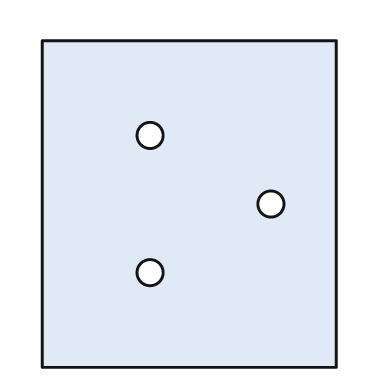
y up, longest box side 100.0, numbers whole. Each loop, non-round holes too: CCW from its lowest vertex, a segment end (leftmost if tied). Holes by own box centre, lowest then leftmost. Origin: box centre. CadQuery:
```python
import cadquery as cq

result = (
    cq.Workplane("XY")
    .moveTo(-45.0, -50.0)
    .lineTo(45.0, -50.0)
    .lineTo(45.0, 50.0)
    .lineTo(-45.0, 50.0)
    .close()
    .moveTo(-12.0, -21.0)
    .circle(4.0)
    .moveTo(25.0, 0.0)
    .circle(4.0)
    .moveTo(-12.0, 21.0)
    .circle(4.0)
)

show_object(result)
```